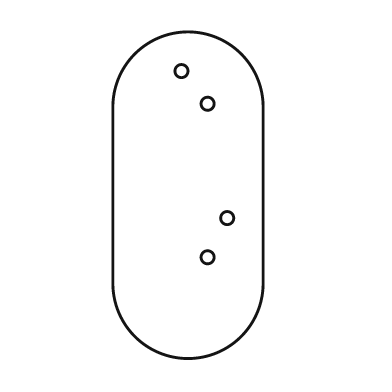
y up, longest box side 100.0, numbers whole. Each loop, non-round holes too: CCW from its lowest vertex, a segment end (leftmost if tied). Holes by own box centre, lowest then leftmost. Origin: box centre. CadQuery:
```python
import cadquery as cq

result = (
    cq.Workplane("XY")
    .moveTo(-23.0, -27.0)
    .threePointArc((0.0, -50.0), (23.0, -27.0))
    .lineTo(23.0, 27.0)
    .threePointArc((0.0, 50.0), (-23.0, 27.0))
    .close()
    .moveTo(6.0, -19.0)
    .circle(2.0)
    .moveTo(12.0, -7.0)
    .circle(2.0)
    .moveTo(6.0, 28.0)
    .circle(2.0)
    .moveTo(-2.0, 38.0)
    .circle(2.0)
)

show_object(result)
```